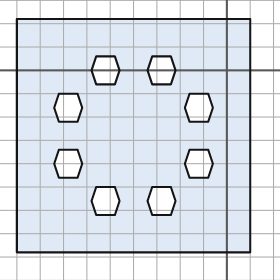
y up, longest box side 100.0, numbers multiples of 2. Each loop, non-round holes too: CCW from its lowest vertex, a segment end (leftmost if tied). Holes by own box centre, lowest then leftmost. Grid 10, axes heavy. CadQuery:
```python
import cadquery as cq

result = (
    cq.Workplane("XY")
    .moveTo(-90.0, -78.0)
    .lineTo(10.0, -78.0)
    .lineTo(10.0, 22.0)
    .lineTo(-90.0, 22.0)
    .close()
    .moveTo(-56.0, -62.0)
    .lineTo(-48.0, -62.0)
    .lineTo(-46.0, -56.0)
    .lineTo(-48.0, -50.0)
    .lineTo(-56.0, -50.0)
    .lineTo(-58.0, -56.0)
    .close()
    .moveTo(-32.0, -62.0)
    .lineTo(-24.0, -62.0)
    .lineTo(-22.0, -56.0)
    .lineTo(-24.0, -50.0)
    .lineTo(-32.0, -50.0)
    .lineTo(-34.0, -56.0)
    .close()
    .moveTo(-72.0, -46.0)
    .lineTo(-64.0, -46.0)
    .lineTo(-62.0, -40.0)
    .lineTo(-64.0, -34.0)
    .lineTo(-72.0, -34.0)
    .lineTo(-74.0, -40.0)
    .close()
    .moveTo(-16.0, -46.0)
    .lineTo(-8.0, -46.0)
    .lineTo(-6.0, -40.0)
    .lineTo(-8.0, -34.0)
    .lineTo(-16.0, -34.0)
    .lineTo(-18.0, -40.0)
    .close()
    .moveTo(-72.0, -22.0)
    .lineTo(-64.0, -22.0)
    .lineTo(-62.0, -16.0)
    .lineTo(-64.0, -10.0)
    .lineTo(-72.0, -10.0)
    .lineTo(-74.0, -16.0)
    .close()
    .moveTo(-16.0, -22.0)
    .lineTo(-8.0, -22.0)
    .lineTo(-6.0, -16.0)
    .lineTo(-8.0, -10.0)
    .lineTo(-16.0, -10.0)
    .lineTo(-18.0, -16.0)
    .close()
    .moveTo(-56.0, -6.0)
    .lineTo(-48.0, -6.0)
    .lineTo(-46.0, 0.0)
    .lineTo(-48.0, 6.0)
    .lineTo(-56.0, 6.0)
    .lineTo(-58.0, 0.0)
    .close()
    .moveTo(-32.0, -6.0)
    .lineTo(-24.0, -6.0)
    .lineTo(-22.0, 0.0)
    .lineTo(-24.0, 6.0)
    .lineTo(-32.0, 6.0)
    .lineTo(-34.0, 0.0)
    .close()
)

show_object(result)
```